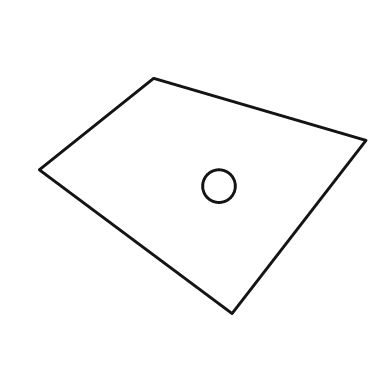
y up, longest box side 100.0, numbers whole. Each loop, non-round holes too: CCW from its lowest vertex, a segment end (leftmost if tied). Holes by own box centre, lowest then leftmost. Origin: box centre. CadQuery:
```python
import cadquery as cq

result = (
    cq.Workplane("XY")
    .moveTo(9.0, -36.0)
    .lineTo(50.0, 17.0)
    .lineTo(-15.0, 36.0)
    .lineTo(-50.0, 8.0)
    .close()
    .moveTo(5.0, 3.0)
    .circle(5.0)
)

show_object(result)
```